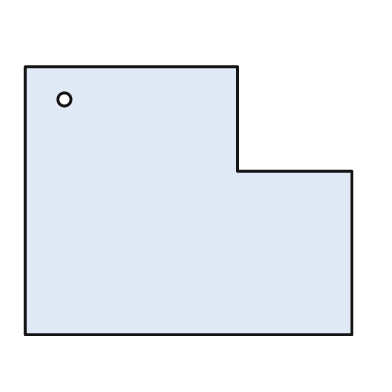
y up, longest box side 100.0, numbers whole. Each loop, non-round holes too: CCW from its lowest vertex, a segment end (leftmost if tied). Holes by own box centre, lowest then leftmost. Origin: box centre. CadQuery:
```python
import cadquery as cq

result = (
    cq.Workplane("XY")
    .moveTo(-50.0, -41.0)
    .lineTo(50.0, -41.0)
    .lineTo(50.0, 9.0)
    .lineTo(15.0, 9.0)
    .lineTo(15.0, 41.0)
    .lineTo(-50.0, 41.0)
    .close()
    .moveTo(-38.0, 31.0)
    .circle(2.0)
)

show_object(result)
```